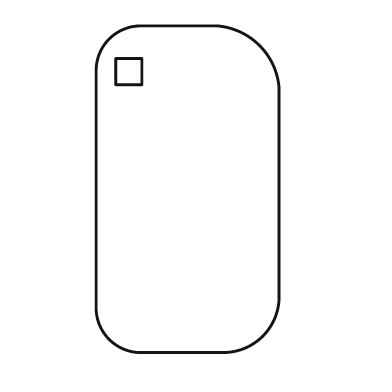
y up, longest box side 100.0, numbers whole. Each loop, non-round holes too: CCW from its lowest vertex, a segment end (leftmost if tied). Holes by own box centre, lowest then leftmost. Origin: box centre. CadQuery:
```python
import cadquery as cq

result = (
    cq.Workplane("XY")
    .moveTo(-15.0, -50.0)
    .lineTo(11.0, -50.0)
    .threePointArc((23.0, -45.0), (28.0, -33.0))
    .lineTo(28.0, 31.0)
    .threePointArc((22.0, 44.0), (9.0, 50.0))
    .lineTo(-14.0, 50.0)
    .threePointArc((-24.0, 46.0), (-28.0, 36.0))
    .lineTo(-28.0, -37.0)
    .threePointArc((-24.0, -46.0), (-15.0, -50.0))
    .close()
    .moveTo(-22.0, 32.0)
    .lineTo(-14.0, 32.0)
    .lineTo(-14.0, 40.0)
    .lineTo(-22.0, 40.0)
    .close()
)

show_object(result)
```